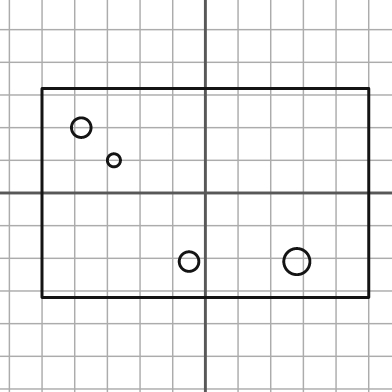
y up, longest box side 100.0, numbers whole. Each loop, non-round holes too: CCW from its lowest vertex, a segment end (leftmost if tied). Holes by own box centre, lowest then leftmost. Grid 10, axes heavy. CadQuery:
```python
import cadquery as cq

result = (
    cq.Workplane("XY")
    .moveTo(-50.0, -32.0)
    .lineTo(50.0, -32.0)
    .lineTo(50.0, 32.0)
    .lineTo(-50.0, 32.0)
    .close()
    .moveTo(-5.0, -21.0)
    .circle(3.0)
    .moveTo(28.0, -21.0)
    .circle(4.0)
    .moveTo(-28.0, 10.0)
    .circle(2.0)
    .moveTo(-38.0, 20.0)
    .circle(3.0)
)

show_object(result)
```